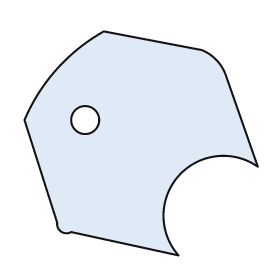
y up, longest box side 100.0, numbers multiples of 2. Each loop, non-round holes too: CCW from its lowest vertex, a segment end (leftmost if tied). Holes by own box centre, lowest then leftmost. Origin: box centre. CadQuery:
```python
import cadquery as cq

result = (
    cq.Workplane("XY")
    .moveTo(16.0, -48.0)
    .threePointArc((16.0, -14.0), (50.0, -10.0))
    .lineTo(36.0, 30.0)
    .threePointArc((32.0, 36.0), (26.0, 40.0))
    .lineTo(-16.0, 48.0)
    .threePointArc((-36.0, 32.0), (-50.0, 10.0))
    .lineTo(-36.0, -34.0)
    .threePointArc((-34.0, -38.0), (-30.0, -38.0))
    .close()
    .moveTo(-24.0, 10.0)
    .circle(6.0)
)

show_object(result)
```